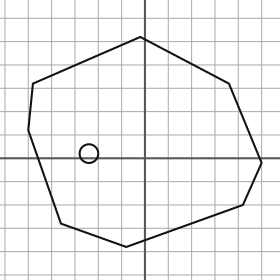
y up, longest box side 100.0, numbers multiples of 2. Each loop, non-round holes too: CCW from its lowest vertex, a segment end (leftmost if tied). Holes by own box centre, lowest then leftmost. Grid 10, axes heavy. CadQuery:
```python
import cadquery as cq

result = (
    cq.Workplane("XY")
    .moveTo(-8.0, -38.0)
    .lineTo(42.0, -20.0)
    .lineTo(50.0, -2.0)
    .lineTo(36.0, 32.0)
    .lineTo(-2.0, 52.0)
    .lineTo(-48.0, 32.0)
    .lineTo(-50.0, 12.0)
    .lineTo(-36.0, -28.0)
    .close()
    .moveTo(-24.0, 2.0)
    .circle(4.0)
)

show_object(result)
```